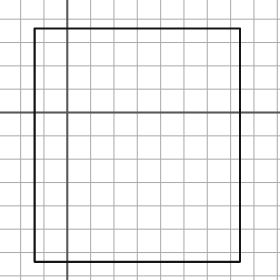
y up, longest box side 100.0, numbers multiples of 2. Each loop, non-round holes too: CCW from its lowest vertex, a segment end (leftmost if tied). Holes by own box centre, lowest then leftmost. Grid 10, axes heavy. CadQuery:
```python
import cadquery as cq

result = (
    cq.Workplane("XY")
    .moveTo(-14.0, -64.0)
    .lineTo(74.0, -64.0)
    .lineTo(74.0, 36.0)
    .lineTo(-14.0, 36.0)
    .close()
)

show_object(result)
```